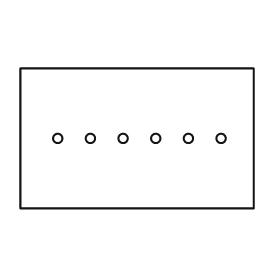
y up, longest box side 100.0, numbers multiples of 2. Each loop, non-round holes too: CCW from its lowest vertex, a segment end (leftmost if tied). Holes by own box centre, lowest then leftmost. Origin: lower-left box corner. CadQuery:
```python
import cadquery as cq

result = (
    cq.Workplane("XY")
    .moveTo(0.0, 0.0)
    .lineTo(100.0, 0.0)
    .lineTo(100.0, 60.0)
    .lineTo(0.0, 60.0)
    .close()
    .moveTo(16.0, 30.0)
    .circle(2.0)
    .moveTo(30.0, 30.0)
    .circle(2.0)
    .moveTo(44.0, 30.0)
    .circle(2.0)
    .moveTo(58.0, 30.0)
    .circle(2.0)
    .moveTo(72.0, 30.0)
    .circle(2.0)
    .moveTo(86.0, 30.0)
    .circle(2.0)
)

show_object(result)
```